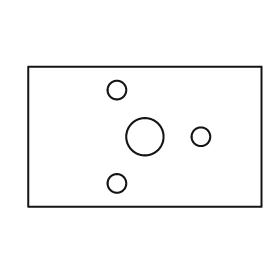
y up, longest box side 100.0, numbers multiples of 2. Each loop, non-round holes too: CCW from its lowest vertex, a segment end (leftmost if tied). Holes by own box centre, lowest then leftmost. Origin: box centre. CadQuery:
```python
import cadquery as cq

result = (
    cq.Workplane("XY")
    .moveTo(-50.0, -30.0)
    .lineTo(50.0, -30.0)
    .lineTo(50.0, 30.0)
    .lineTo(-50.0, 30.0)
    .close()
    .moveTo(-12.0, -20.0)
    .circle(4.0)
    .moveTo(0.0, 0.0)
    .circle(8.0)
    .moveTo(24.0, 0.0)
    .circle(4.0)
    .moveTo(-12.0, 20.0)
    .circle(4.0)
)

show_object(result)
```